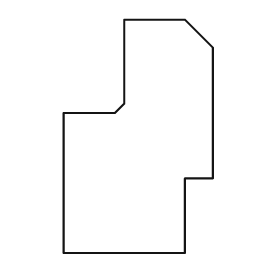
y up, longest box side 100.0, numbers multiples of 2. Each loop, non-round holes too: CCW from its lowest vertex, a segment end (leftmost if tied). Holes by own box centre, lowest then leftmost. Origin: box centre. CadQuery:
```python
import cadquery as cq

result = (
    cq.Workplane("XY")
    .moveTo(-32.0, -50.0)
    .lineTo(20.0, -50.0)
    .lineTo(20.0, -18.0)
    .lineTo(32.0, -18.0)
    .lineTo(32.0, 38.0)
    .lineTo(20.0, 50.0)
    .lineTo(-6.0, 50.0)
    .lineTo(-6.0, 14.0)
    .lineTo(-10.0, 10.0)
    .lineTo(-32.0, 10.0)
    .close()
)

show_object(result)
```